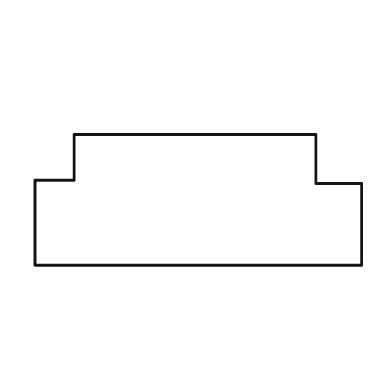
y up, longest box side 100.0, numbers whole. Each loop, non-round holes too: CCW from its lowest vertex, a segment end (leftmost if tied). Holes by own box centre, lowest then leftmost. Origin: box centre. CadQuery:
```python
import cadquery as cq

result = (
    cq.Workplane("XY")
    .moveTo(-50.0, -20.0)
    .lineTo(50.0, -20.0)
    .lineTo(50.0, 5.0)
    .lineTo(36.0, 5.0)
    .lineTo(36.0, 20.0)
    .lineTo(-38.0, 20.0)
    .lineTo(-38.0, 6.0)
    .lineTo(-50.0, 6.0)
    .close()
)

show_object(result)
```